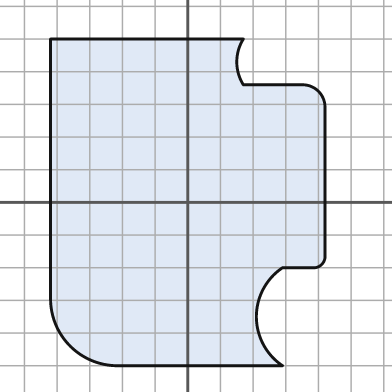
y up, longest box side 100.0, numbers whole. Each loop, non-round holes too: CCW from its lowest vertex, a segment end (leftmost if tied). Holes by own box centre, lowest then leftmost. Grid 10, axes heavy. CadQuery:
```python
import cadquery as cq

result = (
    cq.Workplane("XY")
    .moveTo(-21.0, -50.0)
    .lineTo(29.0, -50.0)
    .threePointArc((21.0, -35.0), (29.0, -20.0))
    .lineTo(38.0, -20.0)
    .threePointArc((41.0, -19.0), (42.0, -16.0))
    .lineTo(42.0, 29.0)
    .threePointArc((40.0, 34.0), (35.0, 36.0))
    .lineTo(17.0, 36.0)
    .threePointArc((15.0, 43.0), (17.0, 50.0))
    .lineTo(-42.0, 50.0)
    .lineTo(-42.0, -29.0)
    .threePointArc((-36.0, -44.0), (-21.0, -50.0))
    .close()
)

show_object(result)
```